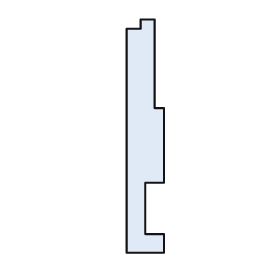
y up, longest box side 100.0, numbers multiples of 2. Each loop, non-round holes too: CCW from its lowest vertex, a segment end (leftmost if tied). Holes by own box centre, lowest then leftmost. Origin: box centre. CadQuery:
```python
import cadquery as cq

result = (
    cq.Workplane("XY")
    .moveTo(-8.0, -50.0)
    .lineTo(8.0, -50.0)
    .lineTo(8.0, -42.0)
    .lineTo(0.0, -42.0)
    .lineTo(0.0, -20.0)
    .lineTo(8.0, -20.0)
    .lineTo(8.0, 12.0)
    .lineTo(4.0, 12.0)
    .lineTo(4.0, 50.0)
    .lineTo(-2.0, 50.0)
    .lineTo(-2.0, 46.0)
    .lineTo(-8.0, 46.0)
    .close()
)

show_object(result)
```